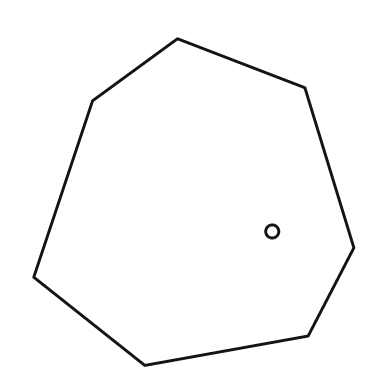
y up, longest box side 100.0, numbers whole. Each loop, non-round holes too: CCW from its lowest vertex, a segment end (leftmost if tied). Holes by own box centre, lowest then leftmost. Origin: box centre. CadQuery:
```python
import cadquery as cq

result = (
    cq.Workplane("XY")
    .moveTo(-15.0, -50.0)
    .lineTo(35.0, -41.0)
    .lineTo(49.0, -14.0)
    .lineTo(34.0, 35.0)
    .lineTo(-5.0, 50.0)
    .lineTo(-31.0, 31.0)
    .lineTo(-49.0, -23.0)
    .close()
    .moveTo(24.0, -9.0)
    .circle(2.0)
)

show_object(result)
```